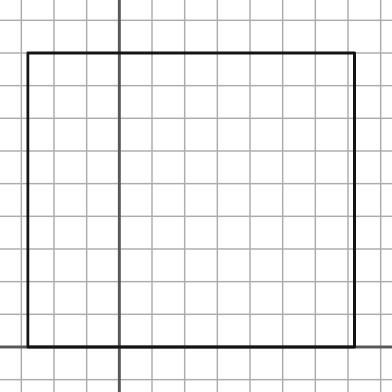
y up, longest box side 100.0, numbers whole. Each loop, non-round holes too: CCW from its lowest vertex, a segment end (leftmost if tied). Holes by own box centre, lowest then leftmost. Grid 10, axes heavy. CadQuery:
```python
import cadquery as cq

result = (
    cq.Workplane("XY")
    .moveTo(-28.0, 0.0)
    .lineTo(72.0, 0.0)
    .lineTo(72.0, 90.0)
    .lineTo(-28.0, 90.0)
    .close()
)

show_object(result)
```